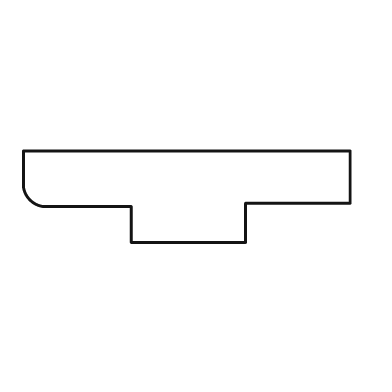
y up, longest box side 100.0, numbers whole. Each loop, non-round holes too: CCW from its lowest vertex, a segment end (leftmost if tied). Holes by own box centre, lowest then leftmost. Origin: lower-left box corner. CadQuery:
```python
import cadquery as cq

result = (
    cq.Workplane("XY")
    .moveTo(33.0, 0.0)
    .lineTo(68.0, 0.0)
    .lineTo(68.0, 12.0)
    .lineTo(100.0, 12.0)
    .lineTo(100.0, 28.0)
    .lineTo(0.0, 28.0)
    .lineTo(0.0, 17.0)
    .threePointArc((2.0, 13.0), (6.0, 11.0))
    .lineTo(33.0, 11.0)
    .close()
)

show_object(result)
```